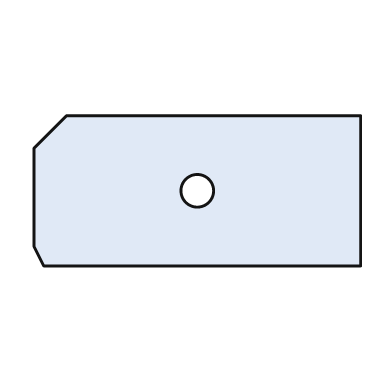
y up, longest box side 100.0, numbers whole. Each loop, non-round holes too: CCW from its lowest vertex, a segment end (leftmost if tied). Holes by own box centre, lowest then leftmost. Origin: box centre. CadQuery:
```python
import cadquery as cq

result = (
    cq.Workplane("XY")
    .moveTo(-47.0, -23.0)
    .lineTo(50.0, -23.0)
    .lineTo(50.0, 23.0)
    .lineTo(-40.0, 23.0)
    .lineTo(-50.0, 13.0)
    .lineTo(-50.0, -17.0)
    .close()
    .moveTo(0.0, 0.0)
    .circle(5.0)
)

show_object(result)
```